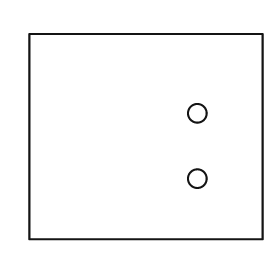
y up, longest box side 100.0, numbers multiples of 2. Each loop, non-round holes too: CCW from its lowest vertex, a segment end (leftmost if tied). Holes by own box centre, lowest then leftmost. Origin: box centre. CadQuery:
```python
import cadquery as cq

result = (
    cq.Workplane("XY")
    .moveTo(-50.0, -44.0)
    .lineTo(50.0, -44.0)
    .lineTo(50.0, 44.0)
    .lineTo(-50.0, 44.0)
    .close()
    .moveTo(22.0, -18.0)
    .circle(4.0)
    .moveTo(22.0, 10.0)
    .circle(4.0)
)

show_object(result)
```